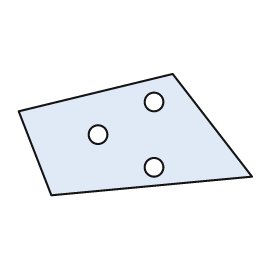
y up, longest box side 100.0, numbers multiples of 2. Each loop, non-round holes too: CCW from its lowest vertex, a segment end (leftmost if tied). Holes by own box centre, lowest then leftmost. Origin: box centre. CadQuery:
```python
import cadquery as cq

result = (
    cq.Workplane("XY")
    .moveTo(-36.0, -26.0)
    .lineTo(50.0, -18.0)
    .lineTo(16.0, 26.0)
    .lineTo(-50.0, 10.0)
    .close()
    .moveTo(8.0, -14.0)
    .circle(4.0)
    .moveTo(-16.0, 0.0)
    .circle(4.0)
    .moveTo(8.0, 14.0)
    .circle(4.0)
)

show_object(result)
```